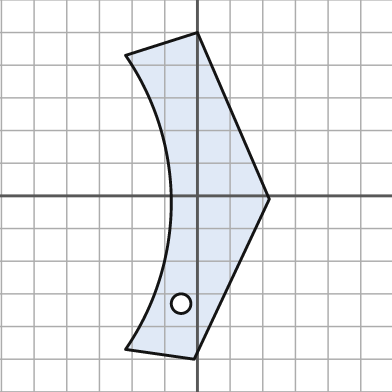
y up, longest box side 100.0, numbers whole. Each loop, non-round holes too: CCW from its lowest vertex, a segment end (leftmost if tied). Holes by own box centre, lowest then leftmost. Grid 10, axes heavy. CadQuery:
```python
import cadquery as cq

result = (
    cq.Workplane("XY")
    .moveTo(-1.0, -50.0)
    .lineTo(22.0, -1.0)
    .lineTo(0.0, 50.0)
    .lineTo(-22.0, 43.0)
    .threePointArc((-8.0, -2.0), (-22.0, -47.0))
    .close()
    .moveTo(-5.0, -33.0)
    .circle(3.0)
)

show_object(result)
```